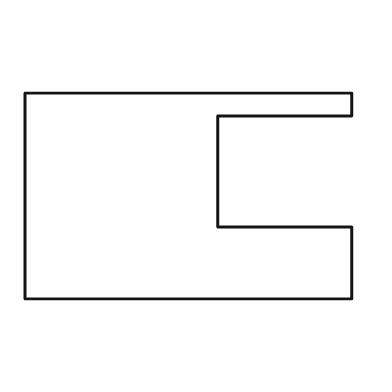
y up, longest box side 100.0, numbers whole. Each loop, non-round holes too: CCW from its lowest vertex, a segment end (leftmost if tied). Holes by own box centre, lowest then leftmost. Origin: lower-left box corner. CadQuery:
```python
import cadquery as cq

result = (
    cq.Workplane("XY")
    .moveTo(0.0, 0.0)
    .lineTo(100.0, 0.0)
    .lineTo(100.0, 22.0)
    .lineTo(59.0, 22.0)
    .lineTo(59.0, 56.0)
    .lineTo(100.0, 56.0)
    .lineTo(100.0, 63.0)
    .lineTo(0.0, 63.0)
    .close()
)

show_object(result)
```